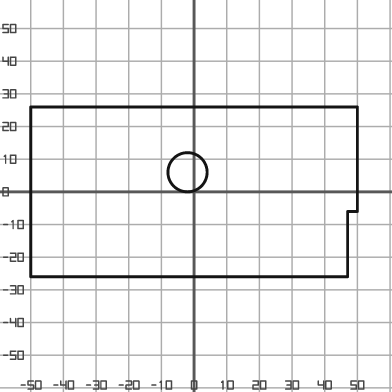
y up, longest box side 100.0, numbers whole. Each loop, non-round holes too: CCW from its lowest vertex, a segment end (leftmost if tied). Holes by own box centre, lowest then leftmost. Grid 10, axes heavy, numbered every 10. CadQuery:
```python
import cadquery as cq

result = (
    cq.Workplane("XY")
    .moveTo(-50.0, -26.0)
    .lineTo(47.0, -26.0)
    .lineTo(47.0, -6.0)
    .lineTo(50.0, -6.0)
    .lineTo(50.0, 26.0)
    .lineTo(-50.0, 26.0)
    .close()
    .moveTo(-2.0, 6.0)
    .circle(6.0)
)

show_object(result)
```